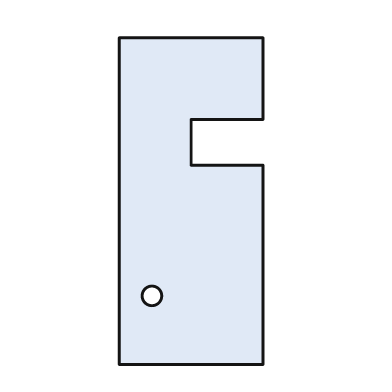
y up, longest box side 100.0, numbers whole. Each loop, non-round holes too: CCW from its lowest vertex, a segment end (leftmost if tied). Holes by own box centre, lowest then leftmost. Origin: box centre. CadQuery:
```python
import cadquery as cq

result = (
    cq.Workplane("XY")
    .moveTo(-22.0, -50.0)
    .lineTo(22.0, -50.0)
    .lineTo(22.0, 11.0)
    .lineTo(0.0, 11.0)
    .lineTo(0.0, 25.0)
    .lineTo(22.0, 25.0)
    .lineTo(22.0, 50.0)
    .lineTo(-22.0, 50.0)
    .close()
    .moveTo(-12.0, -29.0)
    .circle(3.0)
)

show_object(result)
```